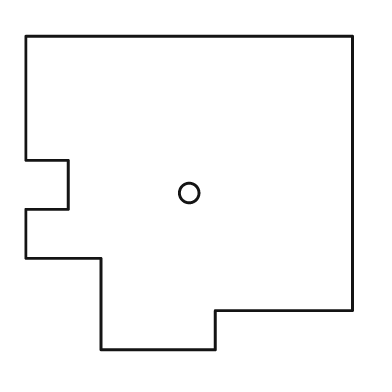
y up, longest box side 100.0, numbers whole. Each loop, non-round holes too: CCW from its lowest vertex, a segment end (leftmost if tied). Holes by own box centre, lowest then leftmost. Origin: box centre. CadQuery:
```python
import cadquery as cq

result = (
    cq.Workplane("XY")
    .moveTo(-27.0, -48.0)
    .lineTo(8.0, -48.0)
    .lineTo(8.0, -36.0)
    .lineTo(50.0, -36.0)
    .lineTo(50.0, 48.0)
    .lineTo(-50.0, 48.0)
    .lineTo(-50.0, 10.0)
    .lineTo(-37.0, 10.0)
    .lineTo(-37.0, -5.0)
    .lineTo(-50.0, -5.0)
    .lineTo(-50.0, -20.0)
    .lineTo(-27.0, -20.0)
    .close()
    .moveTo(0.0, 0.0)
    .circle(3.0)
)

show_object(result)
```